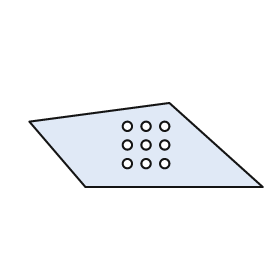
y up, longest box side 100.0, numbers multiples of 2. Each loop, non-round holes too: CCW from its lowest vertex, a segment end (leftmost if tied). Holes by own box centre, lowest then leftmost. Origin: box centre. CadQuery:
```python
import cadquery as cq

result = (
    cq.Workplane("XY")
    .moveTo(-26.0, -18.0)
    .lineTo(50.0, -18.0)
    .lineTo(10.0, 18.0)
    .lineTo(-50.0, 10.0)
    .close()
    .moveTo(-8.0, -8.0)
    .circle(2.0)
    .moveTo(0.0, -8.0)
    .circle(2.0)
    .moveTo(8.0, -8.0)
    .circle(2.0)
    .moveTo(-8.0, 0.0)
    .circle(2.0)
    .moveTo(0.0, 0.0)
    .circle(2.0)
    .moveTo(8.0, 0.0)
    .circle(2.0)
    .moveTo(-8.0, 8.0)
    .circle(2.0)
    .moveTo(0.0, 8.0)
    .circle(2.0)
    .moveTo(8.0, 8.0)
    .circle(2.0)
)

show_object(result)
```